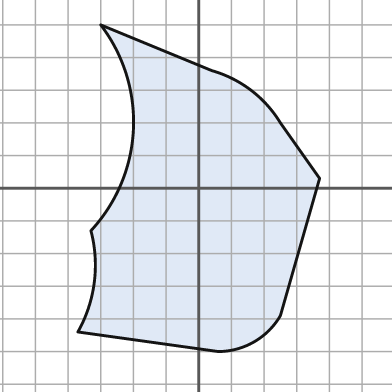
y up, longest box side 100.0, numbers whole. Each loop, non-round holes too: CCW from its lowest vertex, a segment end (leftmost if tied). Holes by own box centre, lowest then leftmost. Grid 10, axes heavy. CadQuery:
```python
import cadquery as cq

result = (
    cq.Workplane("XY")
    .moveTo(6.0, -50.0)
    .threePointArc((17.0, -47.0), (25.0, -39.0))
    .lineTo(37.0, 3.0)
    .lineTo(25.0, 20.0)
    .threePointArc((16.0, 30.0), (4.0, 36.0))
    .lineTo(-30.0, 50.0)
    .threePointArc((-20.0, 18.0), (-33.0, -13.0))
    .threePointArc((-32.0, -29.0), (-37.0, -44.0))
    .close()
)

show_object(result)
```